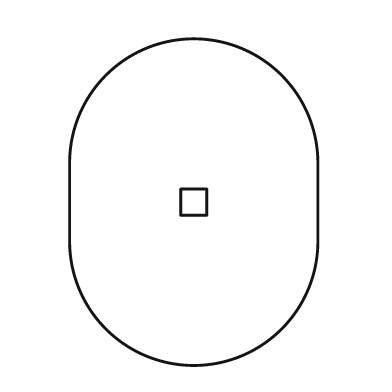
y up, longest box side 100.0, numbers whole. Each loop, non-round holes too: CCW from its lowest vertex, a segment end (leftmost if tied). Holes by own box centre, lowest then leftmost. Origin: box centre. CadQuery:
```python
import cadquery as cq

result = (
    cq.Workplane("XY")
    .moveTo(-38.0, -12.0)
    .threePointArc((0.0, -50.0), (38.0, -12.0))
    .lineTo(38.0, 12.0)
    .threePointArc((0.0, 50.0), (-38.0, 12.0))
    .close()
    .moveTo(-4.0, -4.0)
    .lineTo(4.0, -4.0)
    .lineTo(4.0, 4.0)
    .lineTo(-4.0, 4.0)
    .close()
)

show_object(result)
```